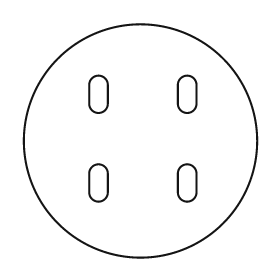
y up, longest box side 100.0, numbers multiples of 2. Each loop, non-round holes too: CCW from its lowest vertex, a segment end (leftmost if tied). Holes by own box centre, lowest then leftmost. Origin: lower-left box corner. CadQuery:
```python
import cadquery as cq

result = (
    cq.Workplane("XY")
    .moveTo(50.0, 50.0)
    .circle(50.0)
    .moveTo(28.0, 28.0)
    .threePointArc((32.0, 24.0), (36.0, 28.0))
    .lineTo(36.0, 36.0)
    .threePointArc((32.0, 40.0), (28.0, 36.0))
    .close()
    .moveTo(66.0, 28.0)
    .threePointArc((70.0, 24.0), (74.0, 28.0))
    .lineTo(74.0, 36.0)
    .threePointArc((70.0, 40.0), (66.0, 36.0))
    .close()
    .moveTo(28.0, 66.0)
    .threePointArc((32.0, 62.0), (36.0, 66.0))
    .lineTo(36.0, 74.0)
    .threePointArc((32.0, 78.0), (28.0, 74.0))
    .close()
    .moveTo(66.0, 66.0)
    .threePointArc((70.0, 62.0), (74.0, 66.0))
    .lineTo(74.0, 74.0)
    .threePointArc((70.0, 78.0), (66.0, 74.0))
    .close()
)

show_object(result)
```